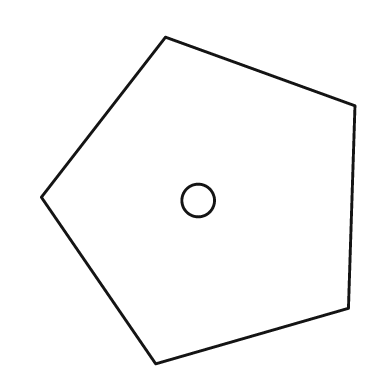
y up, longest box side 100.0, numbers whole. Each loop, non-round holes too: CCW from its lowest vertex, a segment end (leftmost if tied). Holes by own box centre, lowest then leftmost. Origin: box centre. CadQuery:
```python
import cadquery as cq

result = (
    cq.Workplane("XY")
    .moveTo(-13.0, -50.0)
    .lineTo(46.0, -33.0)
    .lineTo(48.0, 29.0)
    .lineTo(-10.0, 50.0)
    .lineTo(-48.0, 1.0)
    .close()
    .moveTo(0.0, 0.0)
    .circle(5.0)
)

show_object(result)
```